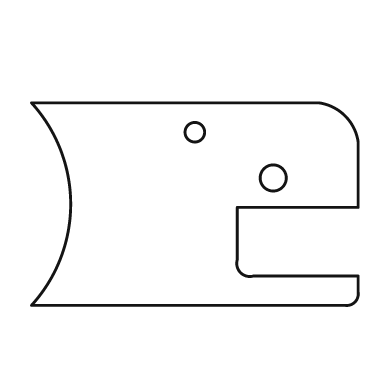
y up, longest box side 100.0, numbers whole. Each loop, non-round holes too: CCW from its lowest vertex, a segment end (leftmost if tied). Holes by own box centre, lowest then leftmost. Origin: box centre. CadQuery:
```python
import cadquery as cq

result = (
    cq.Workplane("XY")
    .moveTo(-50.0, -31.0)
    .lineTo(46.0, -31.0)
    .threePointArc((49.0, -30.0), (50.0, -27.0))
    .lineTo(50.0, -22.0)
    .lineTo(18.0, -22.0)
    .threePointArc((14.0, -21.0), (13.0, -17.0))
    .lineTo(13.0, -1.0)
    .lineTo(50.0, -1.0)
    .lineTo(50.0, 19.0)
    .threePointArc((46.0, 27.0), (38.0, 31.0))
    .lineTo(-50.0, 31.0)
    .threePointArc((-38.0, 0.0), (-50.0, -31.0))
    .close()
    .moveTo(24.0, 8.0)
    .circle(4.0)
    .moveTo(0.0, 22.0)
    .circle(3.0)
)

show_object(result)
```